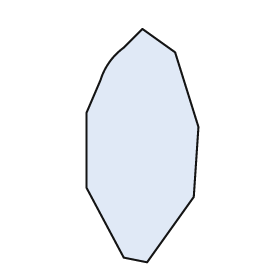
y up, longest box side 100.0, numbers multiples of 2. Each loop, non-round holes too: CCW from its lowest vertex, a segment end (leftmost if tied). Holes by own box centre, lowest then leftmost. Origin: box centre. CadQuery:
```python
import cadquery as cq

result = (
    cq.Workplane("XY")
    .moveTo(2.0, -50.0)
    .lineTo(22.0, -22.0)
    .lineTo(24.0, 8.0)
    .lineTo(14.0, 40.0)
    .lineTo(0.0, 50.0)
    .lineTo(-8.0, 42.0)
    .threePointArc((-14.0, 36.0), (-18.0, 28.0))
    .lineTo(-24.0, 14.0)
    .lineTo(-24.0, -18.0)
    .lineTo(-8.0, -48.0)
    .close()
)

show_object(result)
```